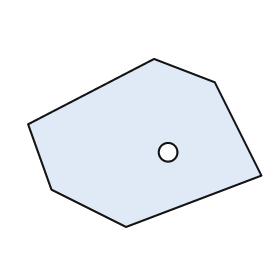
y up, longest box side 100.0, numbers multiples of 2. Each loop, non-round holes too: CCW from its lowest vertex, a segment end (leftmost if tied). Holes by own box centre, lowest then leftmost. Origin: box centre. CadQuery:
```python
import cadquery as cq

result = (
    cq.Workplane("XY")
    .moveTo(-8.0, -36.0)
    .lineTo(50.0, -14.0)
    .lineTo(30.0, 26.0)
    .lineTo(4.0, 36.0)
    .lineTo(-50.0, 8.0)
    .lineTo(-40.0, -20.0)
    .close()
    .moveTo(10.0, -4.0)
    .circle(4.0)
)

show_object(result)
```